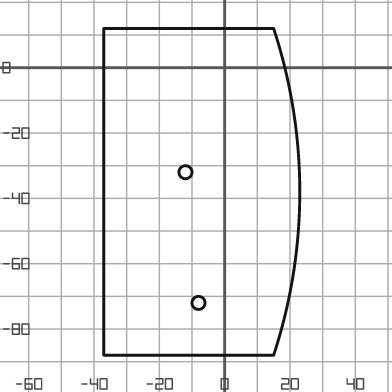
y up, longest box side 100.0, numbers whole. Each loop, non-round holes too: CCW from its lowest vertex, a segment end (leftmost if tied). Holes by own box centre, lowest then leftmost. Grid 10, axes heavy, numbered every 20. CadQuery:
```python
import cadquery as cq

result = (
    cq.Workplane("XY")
    .moveTo(-37.0, -88.0)
    .lineTo(15.0, -88.0)
    .threePointArc((23.0, -38.0), (15.0, 12.0))
    .lineTo(-37.0, 12.0)
    .close()
    .moveTo(-8.0, -72.0)
    .circle(2.0)
    .moveTo(-12.0, -32.0)
    .circle(2.0)
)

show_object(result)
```